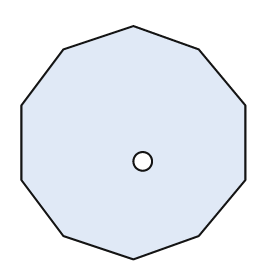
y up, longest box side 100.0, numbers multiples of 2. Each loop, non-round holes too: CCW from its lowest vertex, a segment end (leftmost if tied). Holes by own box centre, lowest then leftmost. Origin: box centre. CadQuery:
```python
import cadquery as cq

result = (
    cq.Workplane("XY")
    .moveTo(0.0, -50.0)
    .lineTo(28.0, -40.0)
    .lineTo(48.0, -16.0)
    .lineTo(48.0, 16.0)
    .lineTo(28.0, 40.0)
    .lineTo(0.0, 50.0)
    .lineTo(-30.0, 40.0)
    .lineTo(-48.0, 16.0)
    .lineTo(-48.0, -16.0)
    .lineTo(-30.0, -40.0)
    .close()
    .moveTo(4.0, -8.0)
    .circle(4.0)
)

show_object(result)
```